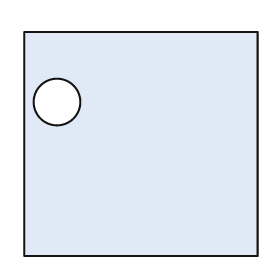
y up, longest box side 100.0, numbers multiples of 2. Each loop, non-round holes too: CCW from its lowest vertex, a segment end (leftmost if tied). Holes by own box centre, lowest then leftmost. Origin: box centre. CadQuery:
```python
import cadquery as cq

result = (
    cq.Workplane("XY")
    .moveTo(-50.0, -48.0)
    .lineTo(50.0, -48.0)
    .lineTo(50.0, 48.0)
    .lineTo(-50.0, 48.0)
    .close()
    .moveTo(-36.0, 18.0)
    .circle(10.0)
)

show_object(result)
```